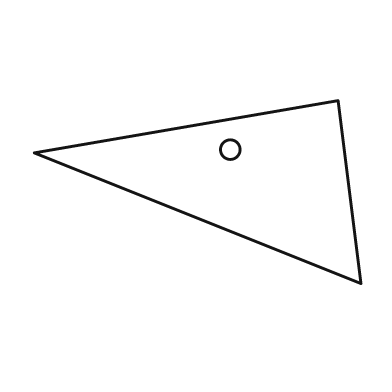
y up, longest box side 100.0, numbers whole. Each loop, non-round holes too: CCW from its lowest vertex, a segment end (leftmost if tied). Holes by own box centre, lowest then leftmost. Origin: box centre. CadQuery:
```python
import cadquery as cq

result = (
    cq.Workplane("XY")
    .moveTo(50.0, -28.0)
    .lineTo(43.0, 28.0)
    .lineTo(-50.0, 12.0)
    .close()
    .moveTo(10.0, 13.0)
    .circle(3.0)
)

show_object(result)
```